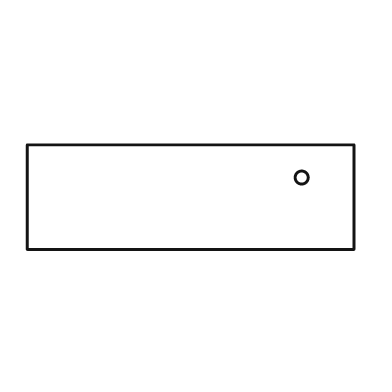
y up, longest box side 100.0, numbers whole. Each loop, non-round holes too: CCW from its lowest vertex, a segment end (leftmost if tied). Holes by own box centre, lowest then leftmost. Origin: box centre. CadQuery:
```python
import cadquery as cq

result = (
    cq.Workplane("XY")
    .moveTo(-50.0, -16.0)
    .lineTo(50.0, -16.0)
    .lineTo(50.0, 16.0)
    .lineTo(-50.0, 16.0)
    .close()
    .moveTo(34.0, 6.0)
    .circle(2.0)
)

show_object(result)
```